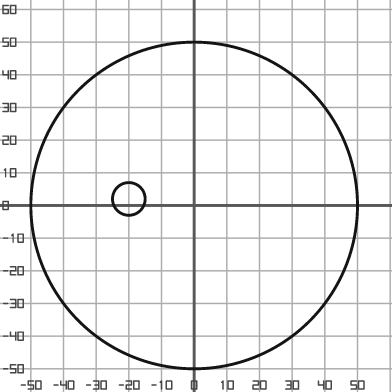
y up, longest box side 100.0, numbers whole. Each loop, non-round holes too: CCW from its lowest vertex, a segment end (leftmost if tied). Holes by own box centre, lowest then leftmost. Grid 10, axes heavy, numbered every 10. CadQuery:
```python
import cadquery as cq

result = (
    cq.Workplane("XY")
    .moveTo(0.0, 0.0)
    .circle(50.0)
    .moveTo(-20.0, 2.0)
    .circle(5.0)
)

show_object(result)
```